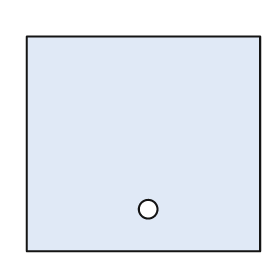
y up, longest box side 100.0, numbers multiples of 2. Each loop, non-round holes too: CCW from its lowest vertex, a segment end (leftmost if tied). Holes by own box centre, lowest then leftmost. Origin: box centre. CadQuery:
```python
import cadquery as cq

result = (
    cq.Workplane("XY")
    .moveTo(-50.0, -46.0)
    .lineTo(50.0, -46.0)
    .lineTo(50.0, 46.0)
    .lineTo(-50.0, 46.0)
    .close()
    .moveTo(2.0, -28.0)
    .circle(4.0)
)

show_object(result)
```